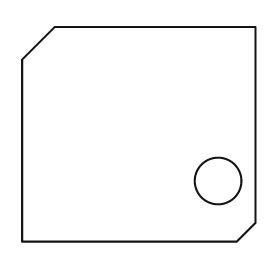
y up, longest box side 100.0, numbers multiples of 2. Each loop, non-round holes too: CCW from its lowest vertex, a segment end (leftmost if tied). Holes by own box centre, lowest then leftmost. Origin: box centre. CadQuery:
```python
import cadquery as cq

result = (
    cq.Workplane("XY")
    .moveTo(-50.0, -46.0)
    .lineTo(42.0, -46.0)
    .lineTo(50.0, -38.0)
    .lineTo(50.0, 46.0)
    .lineTo(-36.0, 46.0)
    .lineTo(-50.0, 32.0)
    .close()
    .moveTo(34.0, -20.0)
    .circle(10.0)
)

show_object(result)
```